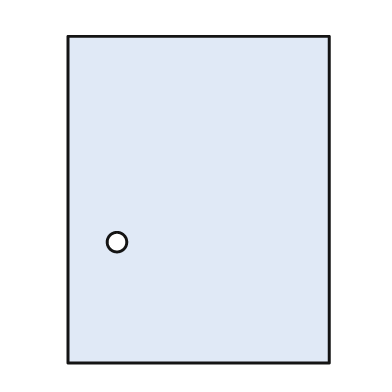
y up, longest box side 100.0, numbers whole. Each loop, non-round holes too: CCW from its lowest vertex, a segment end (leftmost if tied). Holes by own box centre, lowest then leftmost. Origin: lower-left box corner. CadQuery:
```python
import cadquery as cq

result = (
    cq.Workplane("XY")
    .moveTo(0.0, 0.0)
    .lineTo(80.0, 0.0)
    .lineTo(80.0, 100.0)
    .lineTo(0.0, 100.0)
    .close()
    .moveTo(15.0, 37.0)
    .circle(3.0)
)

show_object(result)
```